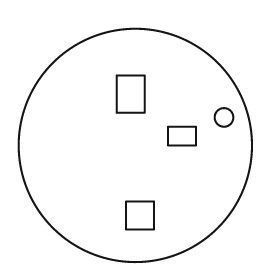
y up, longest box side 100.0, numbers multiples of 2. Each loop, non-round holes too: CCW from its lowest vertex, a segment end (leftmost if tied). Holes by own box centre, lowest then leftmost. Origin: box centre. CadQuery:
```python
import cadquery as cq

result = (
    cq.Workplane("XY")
    .moveTo(0.0, 0.0)
    .circle(50.0)
    .moveTo(-4.0, -36.0)
    .lineTo(8.0, -36.0)
    .lineTo(8.0, -24.0)
    .lineTo(-4.0, -24.0)
    .close()
    .moveTo(14.0, 0.0)
    .lineTo(26.0, 0.0)
    .lineTo(26.0, 8.0)
    .lineTo(14.0, 8.0)
    .close()
    .moveTo(38.0, 12.0)
    .circle(4.0)
    .moveTo(-8.0, 14.0)
    .lineTo(4.0, 14.0)
    .lineTo(4.0, 30.0)
    .lineTo(-8.0, 30.0)
    .close()
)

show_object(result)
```